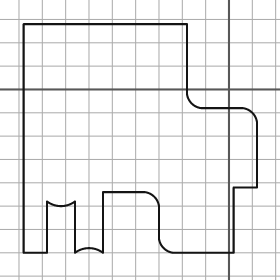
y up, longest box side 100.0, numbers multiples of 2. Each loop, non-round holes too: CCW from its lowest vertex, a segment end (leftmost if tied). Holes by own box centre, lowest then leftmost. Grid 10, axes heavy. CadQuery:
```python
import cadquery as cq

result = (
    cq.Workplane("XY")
    .moveTo(-88.0, -70.0)
    .lineTo(-78.0, -70.0)
    .lineTo(-78.0, -48.0)
    .threePointArc((-72.0, -50.0), (-66.0, -48.0))
    .lineTo(-66.0, -70.0)
    .threePointArc((-60.0, -68.0), (-54.0, -70.0))
    .lineTo(-54.0, -44.0)
    .lineTo(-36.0, -44.0)
    .threePointArc((-32.0, -46.0), (-30.0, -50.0))
    .lineTo(-30.0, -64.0)
    .threePointArc((-28.0, -68.0), (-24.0, -70.0))
    .lineTo(2.0, -70.0)
    .lineTo(2.0, -42.0)
    .lineTo(12.0, -42.0)
    .lineTo(12.0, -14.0)
    .threePointArc((10.0, -10.0), (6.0, -8.0))
    .lineTo(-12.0, -8.0)
    .threePointArc((-16.0, -6.0), (-18.0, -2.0))
    .lineTo(-18.0, 28.0)
    .lineTo(-88.0, 28.0)
    .close()
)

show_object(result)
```